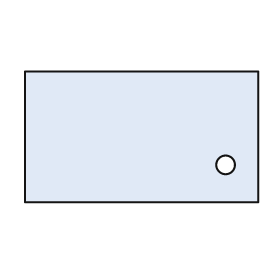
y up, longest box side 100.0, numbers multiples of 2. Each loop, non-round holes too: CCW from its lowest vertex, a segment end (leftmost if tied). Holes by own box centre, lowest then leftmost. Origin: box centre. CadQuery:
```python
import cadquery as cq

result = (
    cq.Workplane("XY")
    .moveTo(-50.0, -28.0)
    .lineTo(50.0, -28.0)
    .lineTo(50.0, 28.0)
    .lineTo(-50.0, 28.0)
    .close()
    .moveTo(36.0, -12.0)
    .circle(4.0)
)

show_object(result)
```